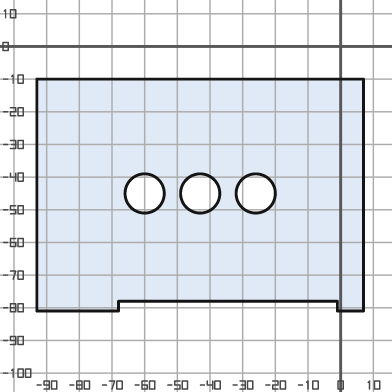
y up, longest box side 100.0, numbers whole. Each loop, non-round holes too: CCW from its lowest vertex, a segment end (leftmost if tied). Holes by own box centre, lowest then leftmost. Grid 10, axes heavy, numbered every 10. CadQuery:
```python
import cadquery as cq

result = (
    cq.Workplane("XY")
    .moveTo(-93.0, -81.0)
    .lineTo(-68.0, -81.0)
    .lineTo(-68.0, -78.0)
    .lineTo(-1.0, -78.0)
    .lineTo(-1.0, -81.0)
    .lineTo(7.0, -81.0)
    .lineTo(7.0, -10.0)
    .lineTo(-93.0, -10.0)
    .close()
    .moveTo(-60.0, -45.0)
    .circle(6.0)
    .moveTo(-43.0, -45.0)
    .circle(6.0)
    .moveTo(-26.0, -45.0)
    .circle(6.0)
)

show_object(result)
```